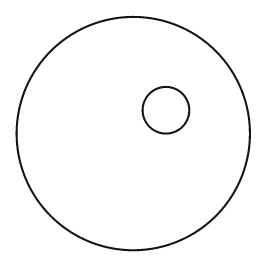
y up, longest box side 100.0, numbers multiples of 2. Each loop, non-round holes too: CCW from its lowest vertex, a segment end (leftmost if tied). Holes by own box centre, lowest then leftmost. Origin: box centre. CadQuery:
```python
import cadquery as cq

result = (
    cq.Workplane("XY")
    .moveTo(0.0, 0.0)
    .circle(50.0)
    .moveTo(14.0, 10.0)
    .circle(10.0)
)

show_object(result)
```